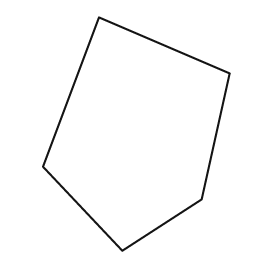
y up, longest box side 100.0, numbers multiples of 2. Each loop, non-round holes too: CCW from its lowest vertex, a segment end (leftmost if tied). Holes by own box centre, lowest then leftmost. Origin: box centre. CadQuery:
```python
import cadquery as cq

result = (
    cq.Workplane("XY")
    .moveTo(-6.0, -50.0)
    .lineTo(28.0, -28.0)
    .lineTo(40.0, 26.0)
    .lineTo(-16.0, 50.0)
    .lineTo(-40.0, -14.0)
    .close()
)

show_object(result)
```